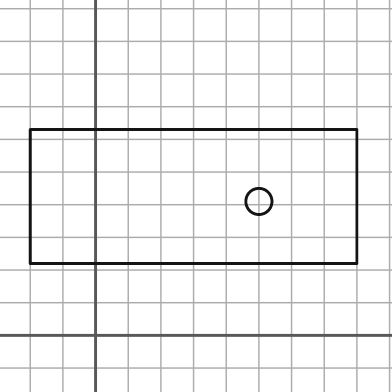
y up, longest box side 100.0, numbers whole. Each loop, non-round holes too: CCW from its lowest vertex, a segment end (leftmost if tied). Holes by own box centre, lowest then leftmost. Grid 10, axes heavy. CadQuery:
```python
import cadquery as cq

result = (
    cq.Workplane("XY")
    .moveTo(-20.0, 22.0)
    .lineTo(80.0, 22.0)
    .lineTo(80.0, 63.0)
    .lineTo(-20.0, 63.0)
    .close()
    .moveTo(50.0, 41.0)
    .circle(4.0)
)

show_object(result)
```